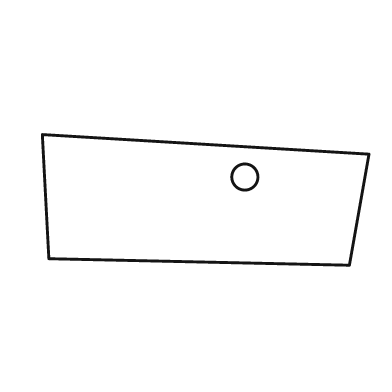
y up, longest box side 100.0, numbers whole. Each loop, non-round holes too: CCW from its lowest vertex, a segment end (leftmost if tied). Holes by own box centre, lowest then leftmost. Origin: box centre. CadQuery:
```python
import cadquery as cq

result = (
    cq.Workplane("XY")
    .moveTo(44.0, -20.0)
    .lineTo(50.0, 14.0)
    .lineTo(-50.0, 20.0)
    .lineTo(-48.0, -18.0)
    .close()
    .moveTo(12.0, 7.0)
    .circle(4.0)
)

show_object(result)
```